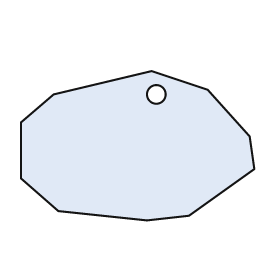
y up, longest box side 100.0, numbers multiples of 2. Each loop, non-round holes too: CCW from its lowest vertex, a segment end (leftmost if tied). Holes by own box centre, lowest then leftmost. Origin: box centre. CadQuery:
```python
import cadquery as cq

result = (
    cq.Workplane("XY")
    .moveTo(4.0, -32.0)
    .lineTo(22.0, -30.0)
    .lineTo(50.0, -10.0)
    .lineTo(48.0, 4.0)
    .lineTo(30.0, 24.0)
    .lineTo(6.0, 32.0)
    .lineTo(-36.0, 22.0)
    .lineTo(-50.0, 10.0)
    .lineTo(-50.0, -14.0)
    .lineTo(-34.0, -28.0)
    .close()
    .moveTo(8.0, 22.0)
    .circle(4.0)
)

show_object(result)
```